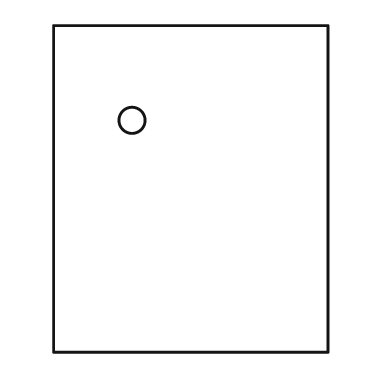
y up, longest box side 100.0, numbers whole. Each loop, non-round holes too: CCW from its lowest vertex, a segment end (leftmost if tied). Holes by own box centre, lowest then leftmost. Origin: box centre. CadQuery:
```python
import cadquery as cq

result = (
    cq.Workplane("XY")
    .moveTo(-42.0, -50.0)
    .lineTo(42.0, -50.0)
    .lineTo(42.0, 50.0)
    .lineTo(-42.0, 50.0)
    .close()
    .moveTo(-18.0, 21.0)
    .circle(4.0)
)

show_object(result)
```